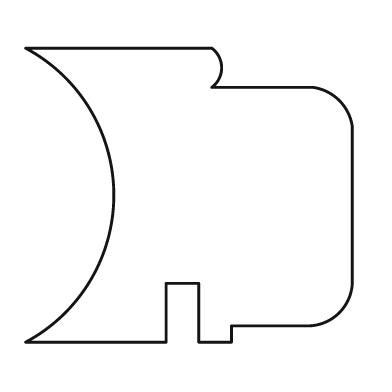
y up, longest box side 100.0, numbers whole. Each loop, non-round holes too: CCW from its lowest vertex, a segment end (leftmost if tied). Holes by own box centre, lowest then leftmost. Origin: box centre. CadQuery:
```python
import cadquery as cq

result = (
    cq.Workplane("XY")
    .moveTo(-50.0, -45.0)
    .lineTo(-7.0, -45.0)
    .lineTo(-7.0, -27.0)
    .lineTo(3.0, -27.0)
    .lineTo(3.0, -45.0)
    .lineTo(13.0, -45.0)
    .lineTo(13.0, -40.0)
    .lineTo(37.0, -40.0)
    .threePointArc((46.0, -36.0), (50.0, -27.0))
    .lineTo(50.0, 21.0)
    .threePointArc((46.0, 29.0), (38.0, 33.0))
    .lineTo(7.0, 33.0)
    .threePointArc((10.0, 39.0), (7.0, 45.0))
    .lineTo(-50.0, 45.0)
    .threePointArc((-23.0, 0.0), (-50.0, -45.0))
    .close()
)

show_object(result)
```